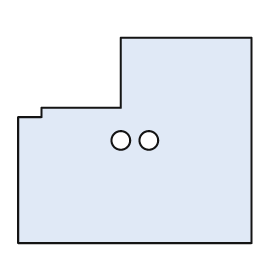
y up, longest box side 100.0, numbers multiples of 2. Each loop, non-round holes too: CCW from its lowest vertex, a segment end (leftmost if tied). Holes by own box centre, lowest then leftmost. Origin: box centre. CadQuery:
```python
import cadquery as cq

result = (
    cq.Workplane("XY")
    .moveTo(-50.0, -44.0)
    .lineTo(50.0, -44.0)
    .lineTo(50.0, 44.0)
    .lineTo(-6.0, 44.0)
    .lineTo(-6.0, 14.0)
    .lineTo(-40.0, 14.0)
    .lineTo(-40.0, 10.0)
    .lineTo(-50.0, 10.0)
    .close()
    .moveTo(-6.0, 0.0)
    .circle(4.0)
    .moveTo(6.0, 0.0)
    .circle(4.0)
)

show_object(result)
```